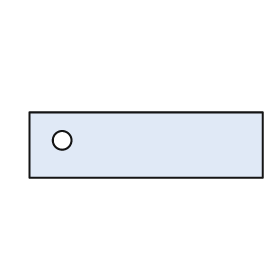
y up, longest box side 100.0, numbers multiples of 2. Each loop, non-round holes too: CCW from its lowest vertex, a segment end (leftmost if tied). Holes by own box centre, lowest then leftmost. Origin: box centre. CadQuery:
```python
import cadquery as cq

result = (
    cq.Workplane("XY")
    .moveTo(-50.0, -14.0)
    .lineTo(50.0, -14.0)
    .lineTo(50.0, 14.0)
    .lineTo(-50.0, 14.0)
    .close()
    .moveTo(-36.0, 2.0)
    .circle(4.0)
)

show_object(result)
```